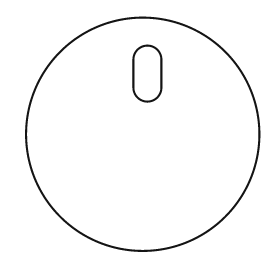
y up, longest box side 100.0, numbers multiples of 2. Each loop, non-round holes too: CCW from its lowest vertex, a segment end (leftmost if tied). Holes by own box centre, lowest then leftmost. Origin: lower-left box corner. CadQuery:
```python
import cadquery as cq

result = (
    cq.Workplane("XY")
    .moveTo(50.0, 50.0)
    .circle(50.0)
    .moveTo(46.0, 70.0)
    .threePointArc((52.0, 64.0), (58.0, 70.0))
    .lineTo(58.0, 82.0)
    .threePointArc((52.0, 88.0), (46.0, 82.0))
    .close()
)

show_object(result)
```